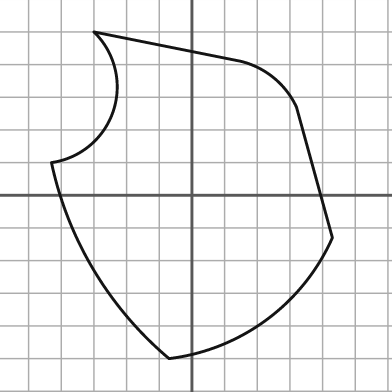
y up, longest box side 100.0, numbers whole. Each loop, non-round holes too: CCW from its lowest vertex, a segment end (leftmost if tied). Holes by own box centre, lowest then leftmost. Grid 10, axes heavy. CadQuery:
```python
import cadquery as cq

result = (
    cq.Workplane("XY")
    .moveTo(-7.0, -50.0)
    .threePointArc((23.0, -38.0), (43.0, -13.0))
    .lineTo(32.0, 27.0)
    .threePointArc((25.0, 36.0), (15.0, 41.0))
    .lineTo(-30.0, 50.0)
    .threePointArc((-24.0, 26.0), (-43.0, 10.0))
    .threePointArc((-30.0, -23.0), (-7.0, -50.0))
    .close()
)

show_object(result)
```